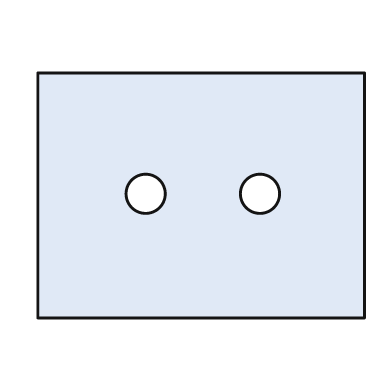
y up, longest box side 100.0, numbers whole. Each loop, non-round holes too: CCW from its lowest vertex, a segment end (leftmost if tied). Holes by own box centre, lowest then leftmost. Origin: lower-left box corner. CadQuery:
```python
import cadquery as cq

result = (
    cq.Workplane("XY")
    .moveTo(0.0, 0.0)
    .lineTo(100.0, 0.0)
    .lineTo(100.0, 75.0)
    .lineTo(0.0, 75.0)
    .close()
    .moveTo(33.0, 38.0)
    .circle(6.0)
    .moveTo(68.0, 38.0)
    .circle(6.0)
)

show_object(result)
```